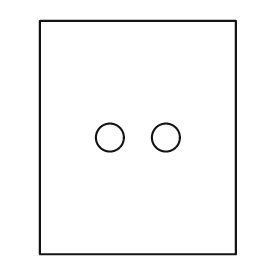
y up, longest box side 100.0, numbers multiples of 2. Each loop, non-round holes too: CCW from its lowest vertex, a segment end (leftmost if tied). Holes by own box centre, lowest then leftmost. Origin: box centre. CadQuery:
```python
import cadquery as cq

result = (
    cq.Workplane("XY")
    .moveTo(-42.0, -50.0)
    .lineTo(42.0, -50.0)
    .lineTo(42.0, 50.0)
    .lineTo(-42.0, 50.0)
    .close()
    .moveTo(-12.0, 0.0)
    .circle(6.0)
    .moveTo(12.0, 0.0)
    .circle(6.0)
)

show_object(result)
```